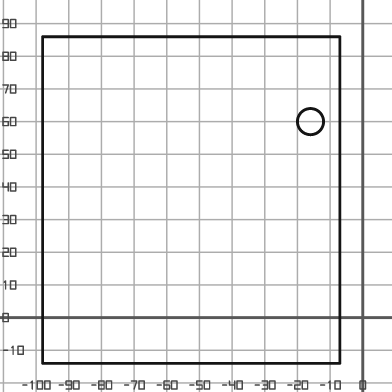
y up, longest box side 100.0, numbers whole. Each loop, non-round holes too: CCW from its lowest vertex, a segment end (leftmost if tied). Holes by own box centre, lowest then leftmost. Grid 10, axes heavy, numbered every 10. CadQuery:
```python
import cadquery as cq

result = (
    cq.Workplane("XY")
    .moveTo(-98.0, -14.0)
    .lineTo(-7.0, -14.0)
    .lineTo(-7.0, 86.0)
    .lineTo(-98.0, 86.0)
    .close()
    .moveTo(-16.0, 60.0)
    .circle(4.0)
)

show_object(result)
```